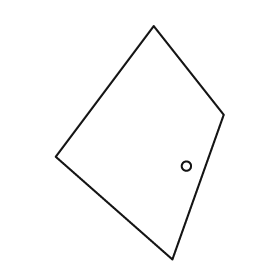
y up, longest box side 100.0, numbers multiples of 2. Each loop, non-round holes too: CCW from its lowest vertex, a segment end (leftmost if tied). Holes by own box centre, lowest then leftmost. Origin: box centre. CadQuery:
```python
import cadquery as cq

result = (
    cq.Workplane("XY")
    .moveTo(14.0, -50.0)
    .lineTo(36.0, 12.0)
    .lineTo(6.0, 50.0)
    .lineTo(-36.0, -6.0)
    .close()
    .moveTo(20.0, -10.0)
    .circle(2.0)
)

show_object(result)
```